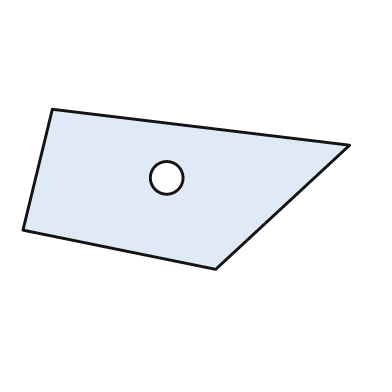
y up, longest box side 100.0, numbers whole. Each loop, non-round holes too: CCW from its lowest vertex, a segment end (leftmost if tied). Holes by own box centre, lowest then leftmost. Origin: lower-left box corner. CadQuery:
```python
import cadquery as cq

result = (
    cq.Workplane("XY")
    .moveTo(59.0, 0.0)
    .lineTo(100.0, 38.0)
    .lineTo(9.0, 49.0)
    .lineTo(0.0, 12.0)
    .close()
    .moveTo(44.0, 28.0)
    .circle(5.0)
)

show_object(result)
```